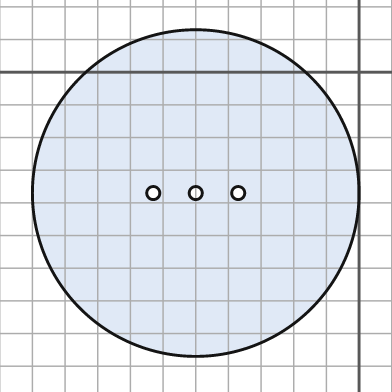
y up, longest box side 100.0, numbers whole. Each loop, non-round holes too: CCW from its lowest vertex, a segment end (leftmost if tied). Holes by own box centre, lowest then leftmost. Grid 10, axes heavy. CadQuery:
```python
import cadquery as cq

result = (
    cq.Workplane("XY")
    .moveTo(-50.0, -37.0)
    .circle(50.0)
    .moveTo(-63.0, -37.0)
    .circle(2.0)
    .moveTo(-50.0, -37.0)
    .circle(2.0)
    .moveTo(-37.0, -37.0)
    .circle(2.0)
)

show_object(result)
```